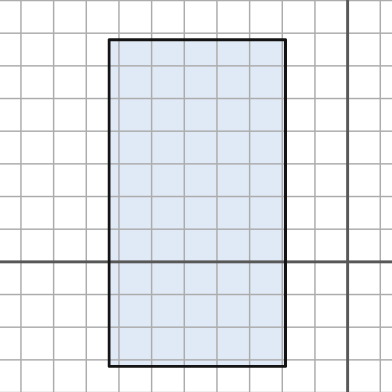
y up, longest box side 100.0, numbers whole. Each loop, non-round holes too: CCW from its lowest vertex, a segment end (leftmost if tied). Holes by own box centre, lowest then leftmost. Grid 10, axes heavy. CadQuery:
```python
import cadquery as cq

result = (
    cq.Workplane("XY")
    .moveTo(-73.0, -32.0)
    .lineTo(-19.0, -32.0)
    .lineTo(-19.0, 68.0)
    .lineTo(-73.0, 68.0)
    .close()
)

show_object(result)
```